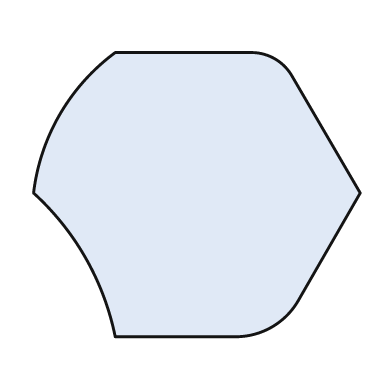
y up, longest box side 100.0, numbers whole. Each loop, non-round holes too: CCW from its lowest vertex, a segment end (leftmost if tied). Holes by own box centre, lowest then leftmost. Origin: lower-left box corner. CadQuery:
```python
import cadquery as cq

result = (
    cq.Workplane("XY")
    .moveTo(25.0, 0.0)
    .lineTo(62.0, 0.0)
    .threePointArc((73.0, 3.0), (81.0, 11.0))
    .lineTo(100.0, 44.0)
    .lineTo(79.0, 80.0)
    .threePointArc((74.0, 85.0), (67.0, 87.0))
    .lineTo(25.0, 87.0)
    .threePointArc((8.0, 68.0), (0.0, 44.0))
    .threePointArc((16.0, 24.0), (25.0, 0.0))
    .close()
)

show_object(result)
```